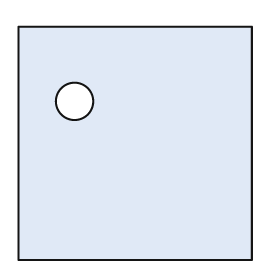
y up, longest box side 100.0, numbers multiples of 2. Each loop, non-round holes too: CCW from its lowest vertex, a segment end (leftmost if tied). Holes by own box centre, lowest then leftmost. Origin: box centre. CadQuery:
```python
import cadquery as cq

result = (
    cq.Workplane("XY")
    .moveTo(-50.0, -50.0)
    .lineTo(50.0, -50.0)
    .lineTo(50.0, 50.0)
    .lineTo(-50.0, 50.0)
    .close()
    .moveTo(-26.0, 18.0)
    .circle(8.0)
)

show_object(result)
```